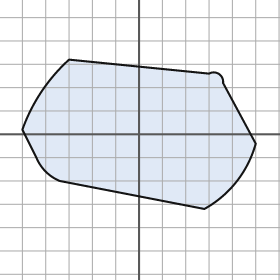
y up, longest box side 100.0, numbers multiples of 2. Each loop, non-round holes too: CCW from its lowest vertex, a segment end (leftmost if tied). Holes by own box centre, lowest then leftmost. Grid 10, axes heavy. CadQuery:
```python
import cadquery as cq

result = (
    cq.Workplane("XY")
    .moveTo(28.0, -32.0)
    .threePointArc((42.0, -20.0), (50.0, -4.0))
    .lineTo(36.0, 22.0)
    .threePointArc((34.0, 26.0), (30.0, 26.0))
    .lineTo(-30.0, 32.0)
    .threePointArc((-42.0, 18.0), (-50.0, 2.0))
    .lineTo(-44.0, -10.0)
    .threePointArc((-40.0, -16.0), (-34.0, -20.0))
    .close()
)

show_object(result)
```